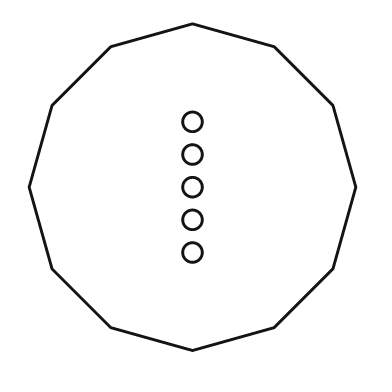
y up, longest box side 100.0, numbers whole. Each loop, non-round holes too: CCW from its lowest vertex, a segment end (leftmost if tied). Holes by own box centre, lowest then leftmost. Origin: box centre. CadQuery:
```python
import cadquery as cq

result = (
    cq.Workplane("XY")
    .moveTo(0.0, -50.0)
    .lineTo(25.0, -43.0)
    .lineTo(43.0, -25.0)
    .lineTo(50.0, 0.0)
    .lineTo(43.0, 25.0)
    .lineTo(25.0, 43.0)
    .lineTo(0.0, 50.0)
    .lineTo(-25.0, 43.0)
    .lineTo(-43.0, 25.0)
    .lineTo(-50.0, 0.0)
    .lineTo(-43.0, -25.0)
    .lineTo(-25.0, -43.0)
    .close()
    .moveTo(0.0, -20.0)
    .circle(3.0)
    .moveTo(0.0, -10.0)
    .circle(3.0)
    .moveTo(0.0, 0.0)
    .circle(3.0)
    .moveTo(0.0, 10.0)
    .circle(3.0)
    .moveTo(0.0, 20.0)
    .circle(3.0)
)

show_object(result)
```